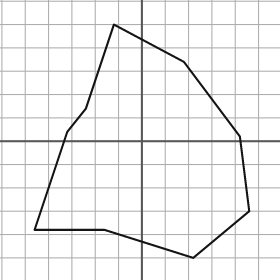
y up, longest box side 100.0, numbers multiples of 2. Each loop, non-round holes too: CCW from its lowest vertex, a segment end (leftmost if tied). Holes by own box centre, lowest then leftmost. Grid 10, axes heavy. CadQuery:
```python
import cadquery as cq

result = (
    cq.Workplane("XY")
    .moveTo(22.0, -50.0)
    .lineTo(46.0, -30.0)
    .lineTo(42.0, 2.0)
    .lineTo(18.0, 34.0)
    .lineTo(-12.0, 50.0)
    .lineTo(-24.0, 14.0)
    .lineTo(-32.0, 4.0)
    .lineTo(-46.0, -38.0)
    .lineTo(-16.0, -38.0)
    .close()
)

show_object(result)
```